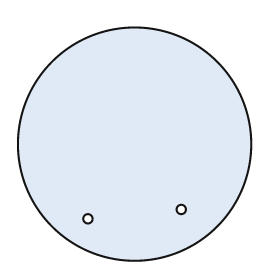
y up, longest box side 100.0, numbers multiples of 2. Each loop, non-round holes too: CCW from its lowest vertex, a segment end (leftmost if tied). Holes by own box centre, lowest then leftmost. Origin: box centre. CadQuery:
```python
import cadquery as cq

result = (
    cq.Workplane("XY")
    .moveTo(0.0, 0.0)
    .circle(50.0)
    .moveTo(-20.0, -32.0)
    .circle(2.0)
    .moveTo(20.0, -28.0)
    .circle(2.0)
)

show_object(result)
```